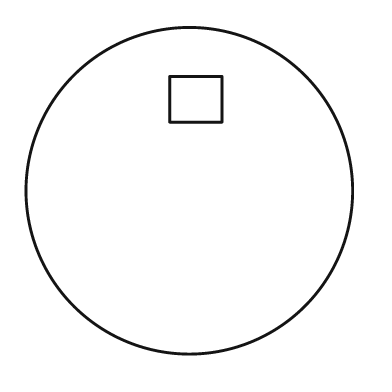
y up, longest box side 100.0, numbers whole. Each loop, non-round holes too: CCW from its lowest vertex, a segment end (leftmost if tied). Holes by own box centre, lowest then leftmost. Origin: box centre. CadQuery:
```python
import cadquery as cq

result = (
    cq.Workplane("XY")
    .moveTo(0.0, 0.0)
    .circle(50.0)
    .moveTo(-6.0, 21.0)
    .lineTo(10.0, 21.0)
    .lineTo(10.0, 35.0)
    .lineTo(-6.0, 35.0)
    .close()
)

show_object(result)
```